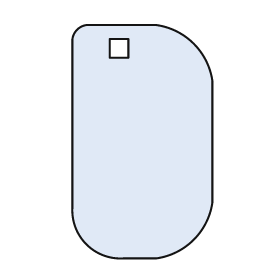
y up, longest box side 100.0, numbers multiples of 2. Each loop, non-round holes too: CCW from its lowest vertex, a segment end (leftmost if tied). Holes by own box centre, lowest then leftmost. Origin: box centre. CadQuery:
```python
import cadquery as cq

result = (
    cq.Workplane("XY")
    .moveTo(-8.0, -50.0)
    .lineTo(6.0, -50.0)
    .threePointArc((22.0, -42.0), (30.0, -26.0))
    .lineTo(30.0, 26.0)
    .threePointArc((22.0, 42.0), (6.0, 50.0))
    .lineTo(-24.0, 50.0)
    .threePointArc((-28.0, 48.0), (-30.0, 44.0))
    .lineTo(-30.0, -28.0)
    .threePointArc((-24.0, -44.0), (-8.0, -50.0))
    .close()
    .moveTo(-14.0, 36.0)
    .lineTo(-6.0, 36.0)
    .lineTo(-6.0, 44.0)
    .lineTo(-14.0, 44.0)
    .close()
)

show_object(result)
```